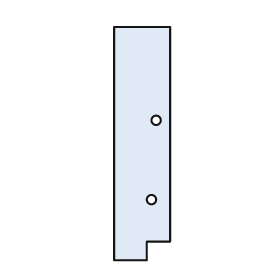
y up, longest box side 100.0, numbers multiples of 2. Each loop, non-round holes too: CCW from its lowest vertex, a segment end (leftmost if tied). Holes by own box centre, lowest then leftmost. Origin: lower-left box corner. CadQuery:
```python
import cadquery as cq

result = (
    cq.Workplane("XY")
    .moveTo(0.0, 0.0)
    .lineTo(14.0, 0.0)
    .lineTo(14.0, 8.0)
    .lineTo(24.0, 8.0)
    .lineTo(24.0, 100.0)
    .lineTo(0.0, 100.0)
    .close()
    .moveTo(16.0, 26.0)
    .circle(2.0)
    .moveTo(18.0, 60.0)
    .circle(2.0)
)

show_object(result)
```